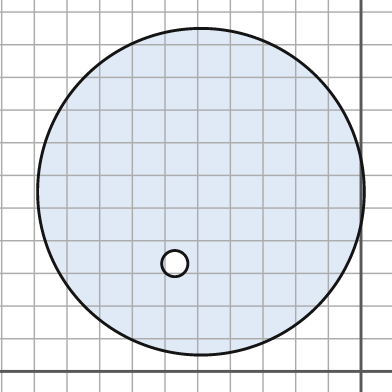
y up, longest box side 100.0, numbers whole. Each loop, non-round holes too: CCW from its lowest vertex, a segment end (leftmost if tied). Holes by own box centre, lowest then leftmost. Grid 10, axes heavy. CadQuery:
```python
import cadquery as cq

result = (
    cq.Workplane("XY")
    .moveTo(-49.0, 55.0)
    .circle(50.0)
    .moveTo(-57.0, 33.0)
    .circle(4.0)
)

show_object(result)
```